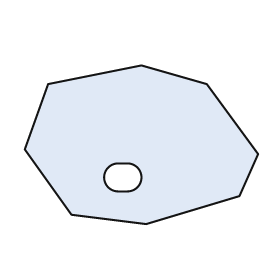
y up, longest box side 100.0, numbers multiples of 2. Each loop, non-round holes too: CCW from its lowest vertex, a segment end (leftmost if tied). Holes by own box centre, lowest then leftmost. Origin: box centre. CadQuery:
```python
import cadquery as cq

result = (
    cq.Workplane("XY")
    .moveTo(2.0, -34.0)
    .lineTo(42.0, -22.0)
    .lineTo(50.0, -4.0)
    .lineTo(28.0, 26.0)
    .lineTo(0.0, 34.0)
    .lineTo(-40.0, 26.0)
    .lineTo(-50.0, -2.0)
    .lineTo(-30.0, -30.0)
    .close()
    .moveTo(-10.0, -20.0)
    .lineTo(-6.0, -20.0)
    .threePointArc((0.0, -14.0), (-6.0, -8.0))
    .lineTo(-10.0, -8.0)
    .threePointArc((-16.0, -14.0), (-10.0, -20.0))
    .close()
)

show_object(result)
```